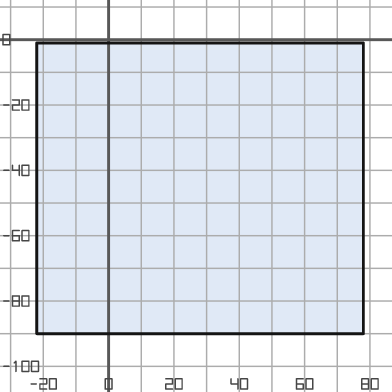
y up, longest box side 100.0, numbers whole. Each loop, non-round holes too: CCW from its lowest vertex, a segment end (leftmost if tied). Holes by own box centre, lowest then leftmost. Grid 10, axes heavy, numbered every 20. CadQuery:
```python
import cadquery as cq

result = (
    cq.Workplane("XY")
    .moveTo(-22.0, -90.0)
    .lineTo(78.0, -90.0)
    .lineTo(78.0, -1.0)
    .lineTo(-22.0, -1.0)
    .close()
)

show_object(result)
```